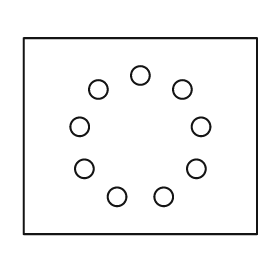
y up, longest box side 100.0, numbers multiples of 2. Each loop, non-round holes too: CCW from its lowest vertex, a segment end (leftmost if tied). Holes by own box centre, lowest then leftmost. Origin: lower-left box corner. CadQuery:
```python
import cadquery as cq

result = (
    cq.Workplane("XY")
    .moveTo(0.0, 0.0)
    .lineTo(100.0, 0.0)
    .lineTo(100.0, 84.0)
    .lineTo(0.0, 84.0)
    .close()
    .moveTo(40.0, 16.0)
    .circle(4.0)
    .moveTo(60.0, 16.0)
    .circle(4.0)
    .moveTo(26.0, 28.0)
    .circle(4.0)
    .moveTo(74.0, 28.0)
    .circle(4.0)
    .moveTo(24.0, 46.0)
    .circle(4.0)
    .moveTo(76.0, 46.0)
    .circle(4.0)
    .moveTo(32.0, 62.0)
    .circle(4.0)
    .moveTo(68.0, 62.0)
    .circle(4.0)
    .moveTo(50.0, 68.0)
    .circle(4.0)
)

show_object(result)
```